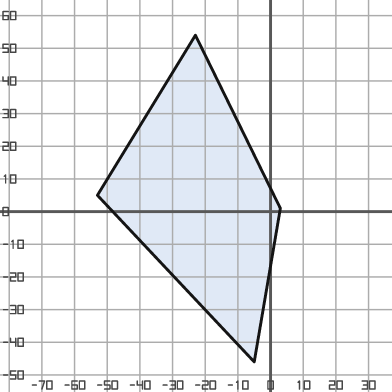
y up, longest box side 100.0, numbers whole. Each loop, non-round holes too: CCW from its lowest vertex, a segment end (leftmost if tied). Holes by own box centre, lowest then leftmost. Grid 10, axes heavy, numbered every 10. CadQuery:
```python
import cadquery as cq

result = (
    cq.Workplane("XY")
    .moveTo(-5.0, -46.0)
    .lineTo(3.0, 1.0)
    .lineTo(-23.0, 54.0)
    .lineTo(-53.0, 5.0)
    .close()
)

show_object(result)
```